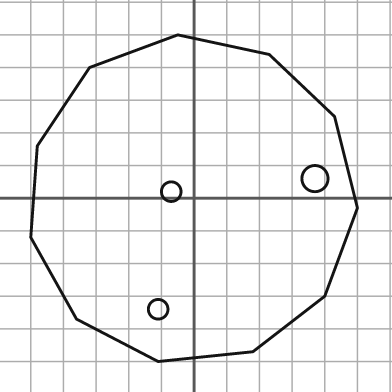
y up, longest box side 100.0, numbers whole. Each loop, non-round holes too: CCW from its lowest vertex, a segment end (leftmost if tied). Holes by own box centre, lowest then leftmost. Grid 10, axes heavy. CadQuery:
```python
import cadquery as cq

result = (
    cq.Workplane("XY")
    .moveTo(-11.0, -50.0)
    .lineTo(18.0, -47.0)
    .lineTo(40.0, -30.0)
    .lineTo(50.0, -3.0)
    .lineTo(43.0, 25.0)
    .lineTo(23.0, 44.0)
    .lineTo(-5.0, 50.0)
    .lineTo(-32.0, 40.0)
    .lineTo(-48.0, 16.0)
    .lineTo(-50.0, -12.0)
    .lineTo(-36.0, -37.0)
    .close()
    .moveTo(-11.0, -34.0)
    .circle(3.0)
    .moveTo(-7.0, 2.0)
    .circle(3.0)
    .moveTo(37.0, 6.0)
    .circle(4.0)
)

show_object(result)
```